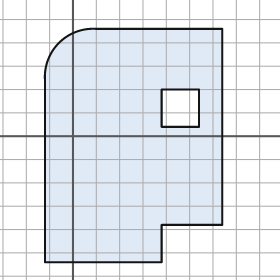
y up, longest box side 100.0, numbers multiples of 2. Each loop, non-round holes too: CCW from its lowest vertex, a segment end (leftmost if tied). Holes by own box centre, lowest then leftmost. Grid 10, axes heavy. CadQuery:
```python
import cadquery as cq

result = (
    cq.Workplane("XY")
    .moveTo(-12.0, -54.0)
    .lineTo(38.0, -54.0)
    .lineTo(38.0, -38.0)
    .lineTo(64.0, -38.0)
    .lineTo(64.0, 46.0)
    .lineTo(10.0, 46.0)
    .threePointArc((-6.0, 40.0), (-12.0, 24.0))
    .close()
    .moveTo(38.0, 4.0)
    .lineTo(54.0, 4.0)
    .lineTo(54.0, 20.0)
    .lineTo(38.0, 20.0)
    .close()
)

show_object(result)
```